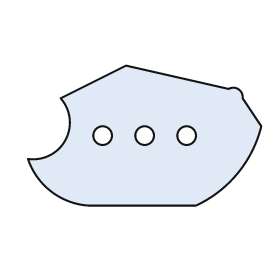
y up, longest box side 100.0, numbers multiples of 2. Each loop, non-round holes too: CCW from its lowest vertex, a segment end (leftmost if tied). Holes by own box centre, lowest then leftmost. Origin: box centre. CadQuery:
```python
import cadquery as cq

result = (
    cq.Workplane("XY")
    .moveTo(-24.0, -30.0)
    .lineTo(22.0, -30.0)
    .threePointArc((40.0, -16.0), (50.0, 4.0))
    .lineTo(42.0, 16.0)
    .threePointArc((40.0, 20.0), (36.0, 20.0))
    .lineTo(-8.0, 30.0)
    .lineTo(-36.0, 16.0)
    .threePointArc((-34.0, -2.0), (-50.0, -10.0))
    .threePointArc((-40.0, -24.0), (-24.0, -30.0))
    .close()
    .moveTo(-18.0, 0.0)
    .circle(4.0)
    .moveTo(0.0, 0.0)
    .circle(4.0)
    .moveTo(18.0, 0.0)
    .circle(4.0)
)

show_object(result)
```